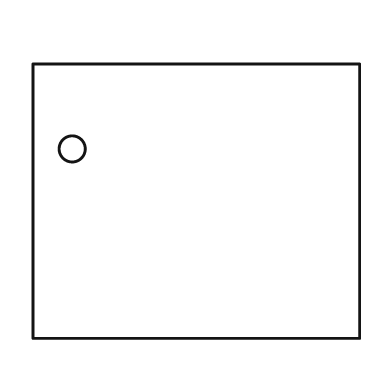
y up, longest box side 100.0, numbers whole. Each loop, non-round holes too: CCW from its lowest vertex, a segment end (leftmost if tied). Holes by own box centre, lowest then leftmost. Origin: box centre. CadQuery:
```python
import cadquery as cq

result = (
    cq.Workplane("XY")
    .moveTo(-50.0, -42.0)
    .lineTo(50.0, -42.0)
    .lineTo(50.0, 42.0)
    .lineTo(-50.0, 42.0)
    .close()
    .moveTo(-38.0, 16.0)
    .circle(4.0)
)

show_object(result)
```